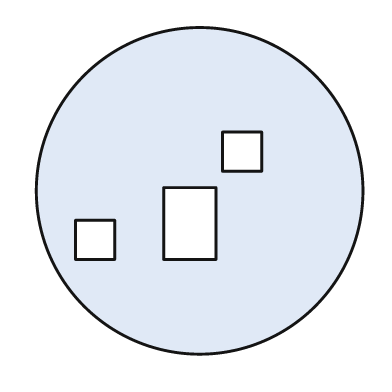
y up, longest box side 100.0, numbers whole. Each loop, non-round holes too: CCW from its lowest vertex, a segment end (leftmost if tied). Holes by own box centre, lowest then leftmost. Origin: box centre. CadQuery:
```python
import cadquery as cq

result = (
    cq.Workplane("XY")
    .moveTo(0.0, 0.0)
    .circle(50.0)
    .moveTo(-38.0, -21.0)
    .lineTo(-26.0, -21.0)
    .lineTo(-26.0, -9.0)
    .lineTo(-38.0, -9.0)
    .close()
    .moveTo(-11.0, -21.0)
    .lineTo(5.0, -21.0)
    .lineTo(5.0, 1.0)
    .lineTo(-11.0, 1.0)
    .close()
    .moveTo(7.0, 6.0)
    .lineTo(19.0, 6.0)
    .lineTo(19.0, 18.0)
    .lineTo(7.0, 18.0)
    .close()
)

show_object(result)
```